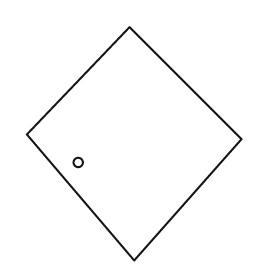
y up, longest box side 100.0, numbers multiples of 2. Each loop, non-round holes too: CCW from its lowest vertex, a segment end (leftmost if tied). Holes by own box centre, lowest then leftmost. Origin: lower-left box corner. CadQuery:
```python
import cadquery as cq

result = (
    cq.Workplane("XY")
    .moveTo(46.0, 0.0)
    .lineTo(92.0, 52.0)
    .lineTo(44.0, 100.0)
    .lineTo(0.0, 54.0)
    .close()
    .moveTo(22.0, 42.0)
    .circle(2.0)
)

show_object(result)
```